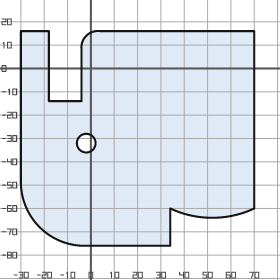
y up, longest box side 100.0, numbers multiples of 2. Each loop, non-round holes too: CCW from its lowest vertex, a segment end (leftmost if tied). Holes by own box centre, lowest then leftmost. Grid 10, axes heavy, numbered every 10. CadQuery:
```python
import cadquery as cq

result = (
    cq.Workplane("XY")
    .moveTo(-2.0, -76.0)
    .lineTo(34.0, -76.0)
    .lineTo(34.0, -60.0)
    .threePointArc((52.0, -64.0), (70.0, -60.0))
    .lineTo(70.0, 16.0)
    .lineTo(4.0, 16.0)
    .threePointArc((-2.0, 14.0), (-4.0, 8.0))
    .lineTo(-4.0, -14.0)
    .lineTo(-18.0, -14.0)
    .lineTo(-18.0, 16.0)
    .lineTo(-30.0, 16.0)
    .lineTo(-30.0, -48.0)
    .threePointArc((-22.0, -68.0), (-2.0, -76.0))
    .close()
    .moveTo(-2.0, -32.0)
    .circle(4.0)
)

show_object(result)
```